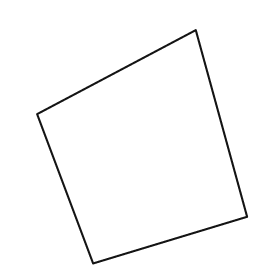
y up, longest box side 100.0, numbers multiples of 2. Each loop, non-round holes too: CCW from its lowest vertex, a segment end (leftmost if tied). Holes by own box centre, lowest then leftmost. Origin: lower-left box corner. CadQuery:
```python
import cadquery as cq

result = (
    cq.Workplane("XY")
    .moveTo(24.0, 0.0)
    .lineTo(90.0, 20.0)
    .lineTo(68.0, 100.0)
    .lineTo(0.0, 64.0)
    .close()
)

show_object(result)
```